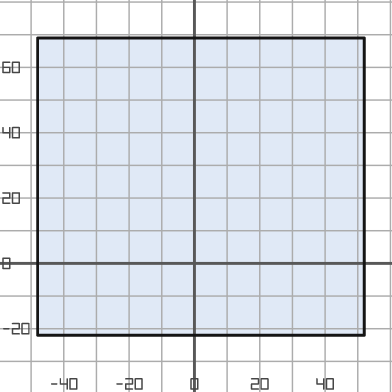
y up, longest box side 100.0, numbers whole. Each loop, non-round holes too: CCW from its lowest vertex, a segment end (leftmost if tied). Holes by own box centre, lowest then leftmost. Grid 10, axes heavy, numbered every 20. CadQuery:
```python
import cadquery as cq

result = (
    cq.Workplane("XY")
    .moveTo(-48.0, -22.0)
    .lineTo(52.0, -22.0)
    .lineTo(52.0, 69.0)
    .lineTo(-48.0, 69.0)
    .close()
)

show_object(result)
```